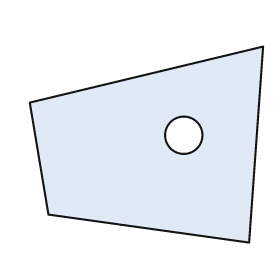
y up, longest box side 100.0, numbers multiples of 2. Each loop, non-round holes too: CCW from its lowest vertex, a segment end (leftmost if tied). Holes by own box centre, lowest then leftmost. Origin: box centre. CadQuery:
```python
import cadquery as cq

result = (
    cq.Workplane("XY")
    .moveTo(44.0, -42.0)
    .lineTo(50.0, 42.0)
    .lineTo(-50.0, 18.0)
    .lineTo(-42.0, -30.0)
    .close()
    .moveTo(16.0, 4.0)
    .circle(8.0)
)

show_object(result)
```